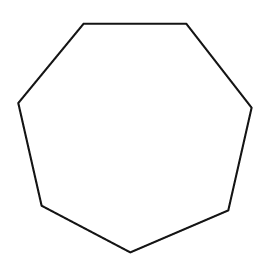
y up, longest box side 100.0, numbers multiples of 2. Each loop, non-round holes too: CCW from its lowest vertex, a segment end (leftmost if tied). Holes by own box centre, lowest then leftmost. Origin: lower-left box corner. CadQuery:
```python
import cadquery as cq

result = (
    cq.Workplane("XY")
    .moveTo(48.0, 0.0)
    .lineTo(90.0, 18.0)
    .lineTo(100.0, 62.0)
    .lineTo(72.0, 98.0)
    .lineTo(28.0, 98.0)
    .lineTo(0.0, 64.0)
    .lineTo(10.0, 20.0)
    .close()
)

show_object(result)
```